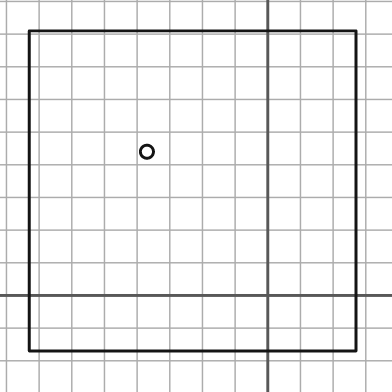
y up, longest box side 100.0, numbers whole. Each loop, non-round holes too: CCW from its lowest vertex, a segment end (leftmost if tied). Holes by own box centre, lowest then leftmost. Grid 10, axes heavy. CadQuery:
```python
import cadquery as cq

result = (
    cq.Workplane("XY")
    .moveTo(-73.0, -17.0)
    .lineTo(27.0, -17.0)
    .lineTo(27.0, 81.0)
    .lineTo(-73.0, 81.0)
    .close()
    .moveTo(-37.0, 44.0)
    .circle(2.0)
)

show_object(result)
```